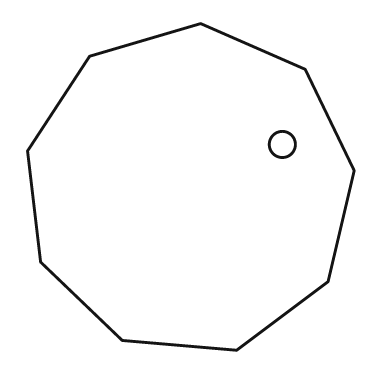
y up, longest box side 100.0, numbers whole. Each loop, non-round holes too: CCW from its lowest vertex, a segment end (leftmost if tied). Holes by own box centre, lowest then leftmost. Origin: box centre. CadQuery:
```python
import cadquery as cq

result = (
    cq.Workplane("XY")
    .moveTo(14.0, -50.0)
    .lineTo(42.0, -29.0)
    .lineTo(50.0, 5.0)
    .lineTo(35.0, 36.0)
    .lineTo(3.0, 50.0)
    .lineTo(-31.0, 40.0)
    .lineTo(-50.0, 11.0)
    .lineTo(-46.0, -23.0)
    .lineTo(-21.0, -47.0)
    .close()
    .moveTo(28.0, 13.0)
    .circle(4.0)
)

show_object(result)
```